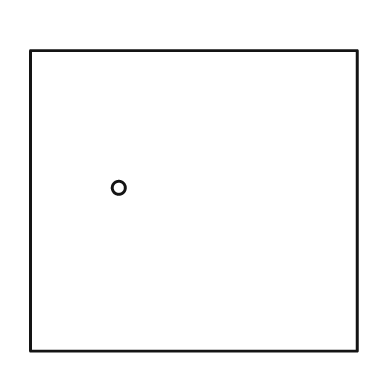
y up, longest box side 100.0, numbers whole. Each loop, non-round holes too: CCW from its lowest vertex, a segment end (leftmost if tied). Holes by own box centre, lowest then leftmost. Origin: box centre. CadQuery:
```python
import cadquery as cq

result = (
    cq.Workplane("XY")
    .moveTo(-50.0, -46.0)
    .lineTo(50.0, -46.0)
    .lineTo(50.0, 46.0)
    .lineTo(-50.0, 46.0)
    .close()
    .moveTo(-23.0, 4.0)
    .circle(2.0)
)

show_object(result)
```